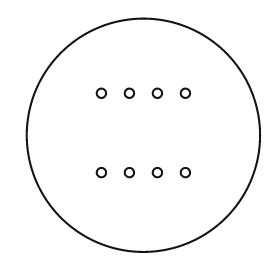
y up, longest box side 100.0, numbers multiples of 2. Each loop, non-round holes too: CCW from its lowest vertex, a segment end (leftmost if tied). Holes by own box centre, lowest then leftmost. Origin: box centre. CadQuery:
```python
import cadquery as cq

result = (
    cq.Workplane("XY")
    .moveTo(0.0, 0.0)
    .circle(50.0)
    .moveTo(-18.0, -16.0)
    .circle(2.0)
    .moveTo(-6.0, -16.0)
    .circle(2.0)
    .moveTo(6.0, -16.0)
    .circle(2.0)
    .moveTo(18.0, -16.0)
    .circle(2.0)
    .moveTo(-18.0, 18.0)
    .circle(2.0)
    .moveTo(-6.0, 18.0)
    .circle(2.0)
    .moveTo(6.0, 18.0)
    .circle(2.0)
    .moveTo(18.0, 18.0)
    .circle(2.0)
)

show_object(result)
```